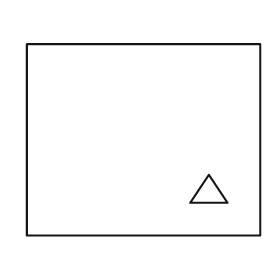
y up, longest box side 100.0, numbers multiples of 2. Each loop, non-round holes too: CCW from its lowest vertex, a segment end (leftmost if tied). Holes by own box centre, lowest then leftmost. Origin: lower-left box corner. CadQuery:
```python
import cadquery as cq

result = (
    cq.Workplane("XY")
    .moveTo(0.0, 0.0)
    .lineTo(100.0, 0.0)
    .lineTo(100.0, 82.0)
    .lineTo(0.0, 82.0)
    .close()
    .moveTo(70.0, 14.0)
    .lineTo(86.0, 14.0)
    .lineTo(78.0, 26.0)
    .close()
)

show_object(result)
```